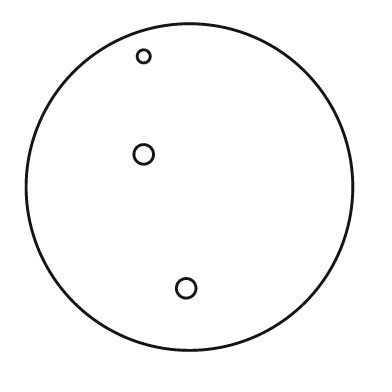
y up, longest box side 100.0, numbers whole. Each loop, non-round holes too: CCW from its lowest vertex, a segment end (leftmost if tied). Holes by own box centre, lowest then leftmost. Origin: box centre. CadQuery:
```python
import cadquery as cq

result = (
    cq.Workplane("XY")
    .moveTo(0.0, 0.0)
    .circle(50.0)
    .moveTo(-1.0, -31.0)
    .circle(3.0)
    .moveTo(-14.0, 10.0)
    .circle(3.0)
    .moveTo(-14.0, 40.0)
    .circle(2.0)
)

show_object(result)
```